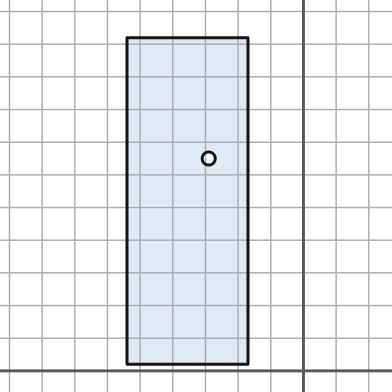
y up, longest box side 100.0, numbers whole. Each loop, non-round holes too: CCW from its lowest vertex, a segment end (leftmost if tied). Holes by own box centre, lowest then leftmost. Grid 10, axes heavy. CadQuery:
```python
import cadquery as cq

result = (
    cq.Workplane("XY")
    .moveTo(-54.0, 2.0)
    .lineTo(-17.0, 2.0)
    .lineTo(-17.0, 102.0)
    .lineTo(-54.0, 102.0)
    .close()
    .moveTo(-29.0, 65.0)
    .circle(2.0)
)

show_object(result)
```